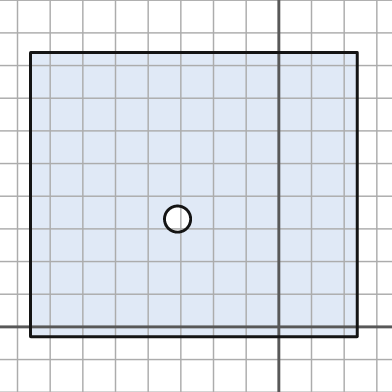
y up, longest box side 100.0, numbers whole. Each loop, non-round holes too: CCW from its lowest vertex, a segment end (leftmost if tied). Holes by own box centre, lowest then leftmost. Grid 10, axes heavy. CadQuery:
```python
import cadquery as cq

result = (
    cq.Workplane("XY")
    .moveTo(-76.0, -3.0)
    .lineTo(24.0, -3.0)
    .lineTo(24.0, 84.0)
    .lineTo(-76.0, 84.0)
    .close()
    .moveTo(-31.0, 33.0)
    .circle(4.0)
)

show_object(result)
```